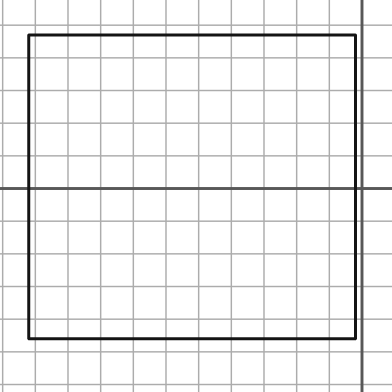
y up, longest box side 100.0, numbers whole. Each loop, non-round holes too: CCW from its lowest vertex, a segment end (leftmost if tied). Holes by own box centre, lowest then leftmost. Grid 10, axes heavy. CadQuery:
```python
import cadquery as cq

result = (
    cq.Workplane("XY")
    .moveTo(-102.0, -46.0)
    .lineTo(-2.0, -46.0)
    .lineTo(-2.0, 47.0)
    .lineTo(-102.0, 47.0)
    .close()
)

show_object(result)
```